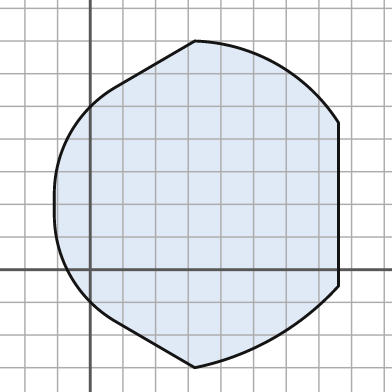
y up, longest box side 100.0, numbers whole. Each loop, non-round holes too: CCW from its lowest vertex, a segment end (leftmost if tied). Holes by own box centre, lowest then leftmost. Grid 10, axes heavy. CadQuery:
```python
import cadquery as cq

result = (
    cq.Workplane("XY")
    .moveTo(32.0, -30.0)
    .threePointArc((56.0, -21.0), (76.0, -5.0))
    .lineTo(76.0, 45.0)
    .threePointArc((57.0, 63.0), (32.0, 70.0))
    .lineTo(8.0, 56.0)
    .threePointArc((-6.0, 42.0), (-11.0, 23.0))
    .lineTo(-11.0, 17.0)
    .threePointArc((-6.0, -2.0), (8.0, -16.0))
    .close()
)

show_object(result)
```